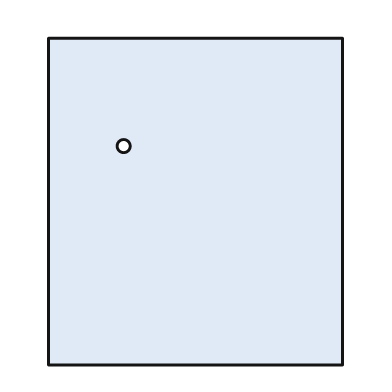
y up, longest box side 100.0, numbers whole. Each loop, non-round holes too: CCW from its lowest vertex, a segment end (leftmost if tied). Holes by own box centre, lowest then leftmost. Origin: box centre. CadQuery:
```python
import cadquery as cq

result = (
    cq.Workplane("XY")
    .moveTo(-45.0, -50.0)
    .lineTo(45.0, -50.0)
    .lineTo(45.0, 50.0)
    .lineTo(-45.0, 50.0)
    .close()
    .moveTo(-22.0, 17.0)
    .circle(2.0)
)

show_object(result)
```